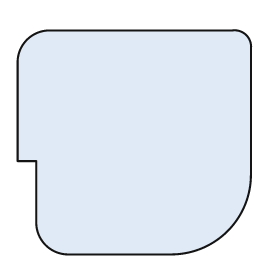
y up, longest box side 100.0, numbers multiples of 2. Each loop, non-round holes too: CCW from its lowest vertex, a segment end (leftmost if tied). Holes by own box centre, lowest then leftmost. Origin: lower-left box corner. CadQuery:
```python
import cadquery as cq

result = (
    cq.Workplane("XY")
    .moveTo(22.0, 0.0)
    .lineTo(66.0, 0.0)
    .threePointArc((90.0, 10.0), (100.0, 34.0))
    .lineTo(100.0, 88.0)
    .threePointArc((98.0, 94.0), (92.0, 96.0))
    .lineTo(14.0, 96.0)
    .threePointArc((4.0, 92.0), (0.0, 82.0))
    .lineTo(0.0, 40.0)
    .lineTo(8.0, 40.0)
    .lineTo(8.0, 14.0)
    .threePointArc((12.0, 4.0), (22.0, 0.0))
    .close()
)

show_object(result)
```